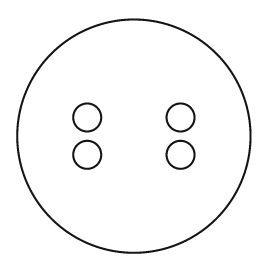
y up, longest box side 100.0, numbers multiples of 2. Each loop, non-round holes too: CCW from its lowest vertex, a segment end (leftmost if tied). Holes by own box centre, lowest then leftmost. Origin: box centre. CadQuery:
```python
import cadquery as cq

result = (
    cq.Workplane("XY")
    .moveTo(0.0, 0.0)
    .circle(50.0)
    .moveTo(-20.0, -8.0)
    .circle(6.0)
    .moveTo(20.0, -8.0)
    .circle(6.0)
    .moveTo(-20.0, 8.0)
    .circle(6.0)
    .moveTo(20.0, 8.0)
    .circle(6.0)
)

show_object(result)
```